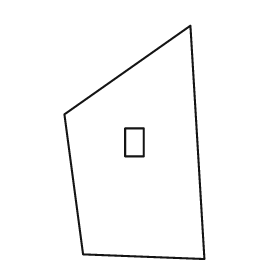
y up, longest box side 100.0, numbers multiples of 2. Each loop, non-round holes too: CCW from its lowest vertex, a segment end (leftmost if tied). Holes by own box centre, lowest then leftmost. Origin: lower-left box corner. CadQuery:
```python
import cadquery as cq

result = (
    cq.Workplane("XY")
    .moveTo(60.0, 0.0)
    .lineTo(54.0, 100.0)
    .lineTo(0.0, 62.0)
    .lineTo(8.0, 2.0)
    .close()
    .moveTo(26.0, 44.0)
    .lineTo(34.0, 44.0)
    .lineTo(34.0, 56.0)
    .lineTo(26.0, 56.0)
    .close()
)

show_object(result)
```